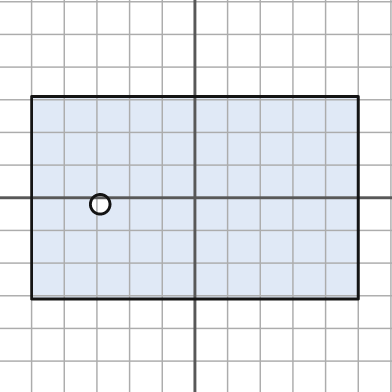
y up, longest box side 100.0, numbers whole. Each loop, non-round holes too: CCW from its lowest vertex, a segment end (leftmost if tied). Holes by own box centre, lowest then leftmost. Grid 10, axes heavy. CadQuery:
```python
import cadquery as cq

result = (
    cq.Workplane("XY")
    .moveTo(-50.0, -31.0)
    .lineTo(50.0, -31.0)
    .lineTo(50.0, 31.0)
    .lineTo(-50.0, 31.0)
    .close()
    .moveTo(-29.0, -2.0)
    .circle(3.0)
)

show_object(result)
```